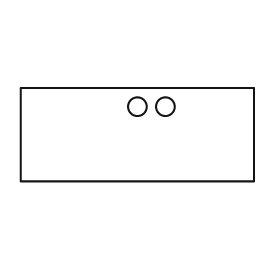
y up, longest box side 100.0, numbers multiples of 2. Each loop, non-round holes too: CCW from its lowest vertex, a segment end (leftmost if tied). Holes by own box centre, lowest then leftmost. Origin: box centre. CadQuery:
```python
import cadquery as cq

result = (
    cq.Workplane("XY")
    .moveTo(-50.0, -20.0)
    .lineTo(50.0, -20.0)
    .lineTo(50.0, 20.0)
    .lineTo(-50.0, 20.0)
    .close()
    .moveTo(0.0, 12.0)
    .circle(4.0)
    .moveTo(12.0, 12.0)
    .circle(4.0)
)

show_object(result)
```